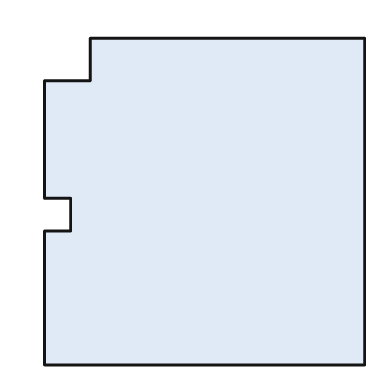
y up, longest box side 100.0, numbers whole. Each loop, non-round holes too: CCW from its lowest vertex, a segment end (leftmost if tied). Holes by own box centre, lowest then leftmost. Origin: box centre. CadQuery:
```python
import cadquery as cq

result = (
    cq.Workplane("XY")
    .moveTo(-49.0, -50.0)
    .lineTo(49.0, -50.0)
    .lineTo(49.0, 50.0)
    .lineTo(-35.0, 50.0)
    .lineTo(-35.0, 37.0)
    .lineTo(-49.0, 37.0)
    .lineTo(-49.0, 1.0)
    .lineTo(-41.0, 1.0)
    .lineTo(-41.0, -9.0)
    .lineTo(-49.0, -9.0)
    .close()
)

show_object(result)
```